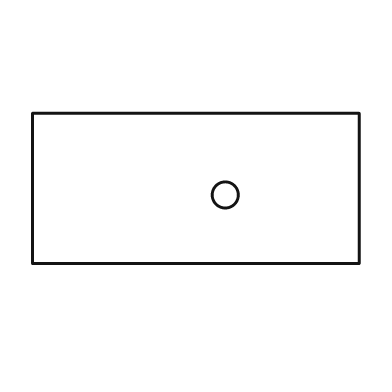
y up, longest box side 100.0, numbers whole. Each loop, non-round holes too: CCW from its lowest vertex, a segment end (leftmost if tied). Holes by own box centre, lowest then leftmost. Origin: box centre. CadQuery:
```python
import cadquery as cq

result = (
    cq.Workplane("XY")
    .moveTo(-50.0, -23.0)
    .lineTo(50.0, -23.0)
    .lineTo(50.0, 23.0)
    .lineTo(-50.0, 23.0)
    .close()
    .moveTo(9.0, -2.0)
    .circle(4.0)
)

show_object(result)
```